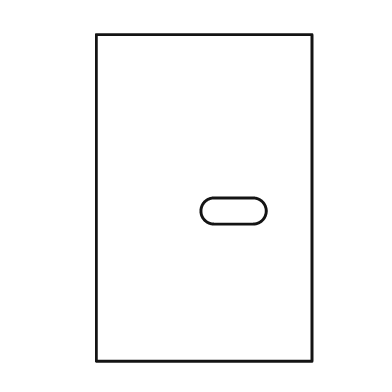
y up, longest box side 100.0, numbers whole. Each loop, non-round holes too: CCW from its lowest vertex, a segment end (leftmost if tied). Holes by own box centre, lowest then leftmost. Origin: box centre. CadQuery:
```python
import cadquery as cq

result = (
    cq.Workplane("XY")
    .moveTo(-33.0, -50.0)
    .lineTo(33.0, -50.0)
    .lineTo(33.0, 50.0)
    .lineTo(-33.0, 50.0)
    .close()
    .moveTo(3.0, -8.0)
    .lineTo(15.0, -8.0)
    .threePointArc((19.0, -4.0), (15.0, 0.0))
    .lineTo(3.0, 0.0)
    .threePointArc((-1.0, -4.0), (3.0, -8.0))
    .close()
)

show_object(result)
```